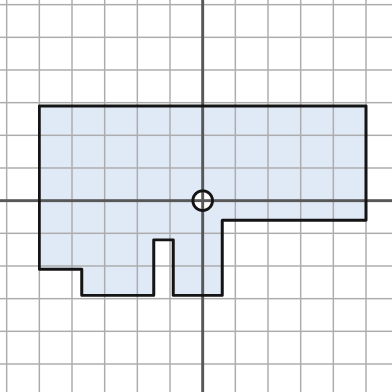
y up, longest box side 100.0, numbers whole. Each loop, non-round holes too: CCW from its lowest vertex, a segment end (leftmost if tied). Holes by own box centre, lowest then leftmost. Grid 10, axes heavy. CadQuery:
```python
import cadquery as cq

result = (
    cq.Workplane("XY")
    .moveTo(-37.0, -29.0)
    .lineTo(-15.0, -29.0)
    .lineTo(-15.0, -12.0)
    .lineTo(-9.0, -12.0)
    .lineTo(-9.0, -29.0)
    .lineTo(6.0, -29.0)
    .lineTo(6.0, -6.0)
    .lineTo(50.0, -6.0)
    .lineTo(50.0, 29.0)
    .lineTo(-50.0, 29.0)
    .lineTo(-50.0, -21.0)
    .lineTo(-37.0, -21.0)
    .close()
    .moveTo(0.0, 0.0)
    .circle(3.0)
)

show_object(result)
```